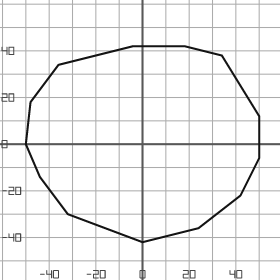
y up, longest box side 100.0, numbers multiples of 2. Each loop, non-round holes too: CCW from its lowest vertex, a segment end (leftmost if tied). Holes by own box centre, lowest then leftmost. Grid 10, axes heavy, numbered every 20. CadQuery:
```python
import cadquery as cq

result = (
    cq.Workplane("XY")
    .moveTo(0.0, -42.0)
    .lineTo(24.0, -36.0)
    .lineTo(42.0, -22.0)
    .lineTo(50.0, -6.0)
    .lineTo(50.0, 12.0)
    .lineTo(34.0, 38.0)
    .lineTo(18.0, 42.0)
    .lineTo(-4.0, 42.0)
    .lineTo(-36.0, 34.0)
    .lineTo(-48.0, 18.0)
    .lineTo(-50.0, 0.0)
    .lineTo(-44.0, -14.0)
    .lineTo(-32.0, -30.0)
    .close()
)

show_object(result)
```